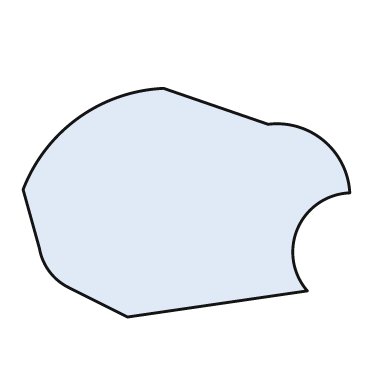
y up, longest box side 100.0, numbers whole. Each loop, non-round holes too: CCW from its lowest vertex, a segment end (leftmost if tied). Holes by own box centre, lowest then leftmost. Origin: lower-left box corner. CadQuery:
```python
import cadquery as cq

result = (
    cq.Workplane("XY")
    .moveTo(32.0, 0.0)
    .lineTo(87.0, 8.0)
    .threePointArc((84.0, 27.0), (100.0, 38.0))
    .threePointArc((92.0, 54.0), (75.0, 59.0))
    .lineTo(43.0, 70.0)
    .threePointArc((17.0, 61.0), (0.0, 39.0))
    .lineTo(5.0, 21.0)
    .threePointArc((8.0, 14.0), (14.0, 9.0))
    .close()
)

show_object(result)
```